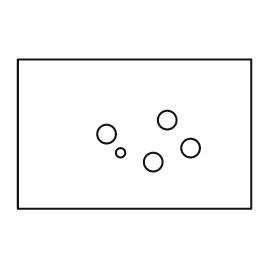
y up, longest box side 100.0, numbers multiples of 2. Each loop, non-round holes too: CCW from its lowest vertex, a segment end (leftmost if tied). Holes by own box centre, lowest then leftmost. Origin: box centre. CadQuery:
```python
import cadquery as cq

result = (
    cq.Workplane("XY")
    .moveTo(-50.0, -32.0)
    .lineTo(50.0, -32.0)
    .lineTo(50.0, 32.0)
    .lineTo(-50.0, 32.0)
    .close()
    .moveTo(8.0, -12.0)
    .circle(4.0)
    .moveTo(-6.0, -8.0)
    .circle(2.0)
    .moveTo(24.0, -6.0)
    .circle(4.0)
    .moveTo(-12.0, 0.0)
    .circle(4.0)
    .moveTo(14.0, 6.0)
    .circle(4.0)
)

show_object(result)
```